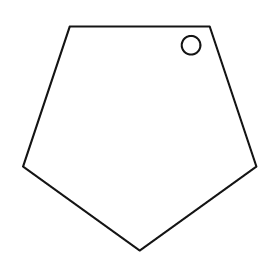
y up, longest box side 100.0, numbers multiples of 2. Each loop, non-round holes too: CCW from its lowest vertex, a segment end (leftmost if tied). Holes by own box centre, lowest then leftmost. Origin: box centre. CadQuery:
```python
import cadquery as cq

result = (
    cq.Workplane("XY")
    .moveTo(0.0, -48.0)
    .lineTo(50.0, -12.0)
    .lineTo(30.0, 48.0)
    .lineTo(-30.0, 48.0)
    .lineTo(-50.0, -12.0)
    .close()
    .moveTo(22.0, 40.0)
    .circle(4.0)
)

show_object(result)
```